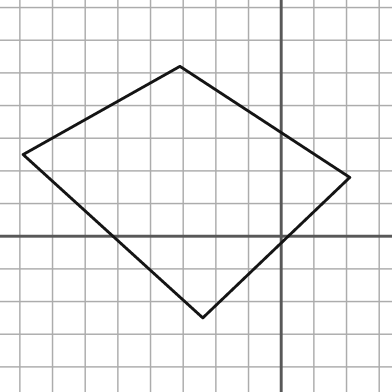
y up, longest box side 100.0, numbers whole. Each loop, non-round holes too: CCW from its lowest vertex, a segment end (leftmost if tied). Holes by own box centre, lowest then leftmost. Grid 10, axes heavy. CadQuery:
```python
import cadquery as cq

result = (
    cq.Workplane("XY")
    .moveTo(-24.0, -25.0)
    .lineTo(21.0, 18.0)
    .lineTo(-31.0, 52.0)
    .lineTo(-79.0, 25.0)
    .close()
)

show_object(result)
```